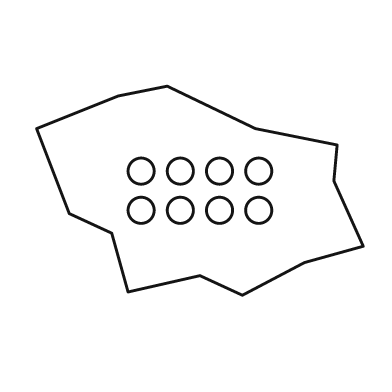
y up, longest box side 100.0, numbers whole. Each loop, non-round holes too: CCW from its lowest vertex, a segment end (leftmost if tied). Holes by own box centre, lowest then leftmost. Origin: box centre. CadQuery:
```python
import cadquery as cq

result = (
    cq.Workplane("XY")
    .moveTo(13.0, -32.0)
    .lineTo(32.0, -22.0)
    .lineTo(50.0, -17.0)
    .lineTo(41.0, 3.0)
    .lineTo(42.0, 14.0)
    .lineTo(17.0, 19.0)
    .lineTo(-10.0, 32.0)
    .lineTo(-25.0, 29.0)
    .lineTo(-50.0, 19.0)
    .lineTo(-40.0, -7.0)
    .lineTo(-27.0, -13.0)
    .lineTo(-22.0, -31.0)
    .lineTo(0.0, -26.0)
    .close()
    .moveTo(-18.0, -6.0)
    .circle(4.0)
    .moveTo(-6.0, -6.0)
    .circle(4.0)
    .moveTo(6.0, -6.0)
    .circle(4.0)
    .moveTo(18.0, -6.0)
    .circle(4.0)
    .moveTo(-18.0, 6.0)
    .circle(4.0)
    .moveTo(-6.0, 6.0)
    .circle(4.0)
    .moveTo(6.0, 6.0)
    .circle(4.0)
    .moveTo(18.0, 6.0)
    .circle(4.0)
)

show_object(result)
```